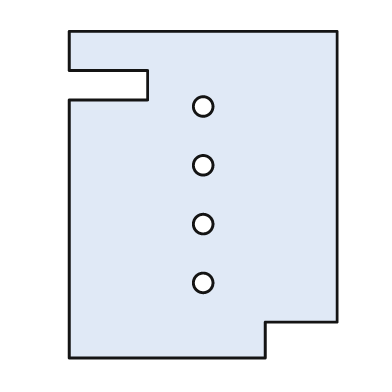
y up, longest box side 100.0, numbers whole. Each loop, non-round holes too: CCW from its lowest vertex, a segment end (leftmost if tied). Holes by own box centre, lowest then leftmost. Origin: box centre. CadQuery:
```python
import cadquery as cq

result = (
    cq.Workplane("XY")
    .moveTo(-41.0, -50.0)
    .lineTo(19.0, -50.0)
    .lineTo(19.0, -39.0)
    .lineTo(41.0, -39.0)
    .lineTo(41.0, 50.0)
    .lineTo(-41.0, 50.0)
    .lineTo(-41.0, 38.0)
    .lineTo(-17.0, 38.0)
    .lineTo(-17.0, 29.0)
    .lineTo(-41.0, 29.0)
    .close()
    .moveTo(0.0, -27.0)
    .circle(3.0)
    .moveTo(0.0, -9.0)
    .circle(3.0)
    .moveTo(0.0, 9.0)
    .circle(3.0)
    .moveTo(0.0, 27.0)
    .circle(3.0)
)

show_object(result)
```